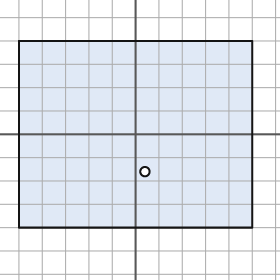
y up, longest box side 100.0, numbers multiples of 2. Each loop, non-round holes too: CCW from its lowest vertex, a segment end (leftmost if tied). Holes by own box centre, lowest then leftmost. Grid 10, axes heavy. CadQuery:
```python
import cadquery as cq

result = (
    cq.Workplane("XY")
    .moveTo(-50.0, -40.0)
    .lineTo(50.0, -40.0)
    .lineTo(50.0, 40.0)
    .lineTo(-50.0, 40.0)
    .close()
    .moveTo(4.0, -16.0)
    .circle(2.0)
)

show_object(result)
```